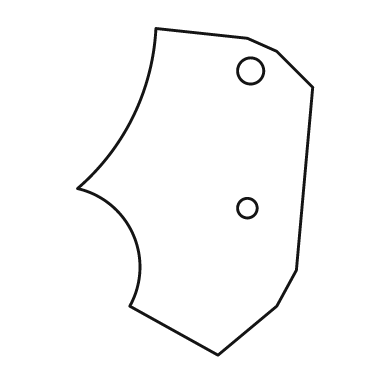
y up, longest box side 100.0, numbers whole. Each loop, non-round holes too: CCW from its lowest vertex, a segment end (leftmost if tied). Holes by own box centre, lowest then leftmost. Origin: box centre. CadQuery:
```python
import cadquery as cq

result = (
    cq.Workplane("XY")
    .moveTo(7.0, -50.0)
    .lineTo(25.0, -35.0)
    .lineTo(31.0, -24.0)
    .lineTo(36.0, 32.0)
    .lineTo(25.0, 43.0)
    .lineTo(16.0, 47.0)
    .lineTo(-12.0, 50.0)
    .threePointArc((-19.0, 23.0), (-36.0, 1.0))
    .threePointArc((-19.0, -13.0), (-20.0, -35.0))
    .close()
    .moveTo(16.0, -5.0)
    .circle(3.0)
    .moveTo(17.0, 37.0)
    .circle(4.0)
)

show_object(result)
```